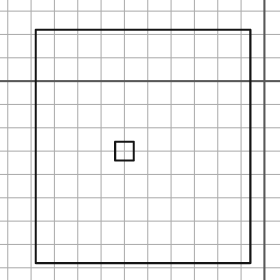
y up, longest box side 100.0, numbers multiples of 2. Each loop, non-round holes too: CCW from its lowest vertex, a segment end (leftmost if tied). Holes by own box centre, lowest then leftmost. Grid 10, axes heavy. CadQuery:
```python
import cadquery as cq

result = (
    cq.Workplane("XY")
    .moveTo(-98.0, -78.0)
    .lineTo(-6.0, -78.0)
    .lineTo(-6.0, 22.0)
    .lineTo(-98.0, 22.0)
    .close()
    .moveTo(-64.0, -34.0)
    .lineTo(-56.0, -34.0)
    .lineTo(-56.0, -26.0)
    .lineTo(-64.0, -26.0)
    .close()
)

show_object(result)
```